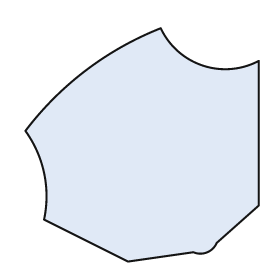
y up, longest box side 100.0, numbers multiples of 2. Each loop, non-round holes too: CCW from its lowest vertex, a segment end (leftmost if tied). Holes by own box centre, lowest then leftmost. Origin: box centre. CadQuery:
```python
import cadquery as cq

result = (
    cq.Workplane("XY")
    .moveTo(-6.0, -50.0)
    .lineTo(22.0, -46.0)
    .threePointArc((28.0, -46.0), (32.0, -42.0))
    .lineTo(50.0, -26.0)
    .lineTo(50.0, 36.0)
    .threePointArc((26.0, 34.0), (8.0, 50.0))
    .threePointArc((-24.0, 32.0), (-50.0, 6.0))
    .threePointArc((-42.0, -12.0), (-42.0, -32.0))
    .close()
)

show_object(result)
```